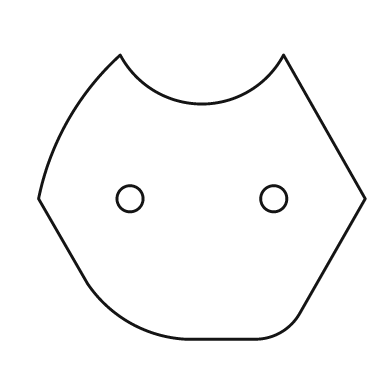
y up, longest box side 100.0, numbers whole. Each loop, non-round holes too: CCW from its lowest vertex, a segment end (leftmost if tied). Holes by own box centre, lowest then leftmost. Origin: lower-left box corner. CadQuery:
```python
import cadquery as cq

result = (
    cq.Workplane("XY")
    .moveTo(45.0, 0.0)
    .lineTo(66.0, 0.0)
    .threePointArc((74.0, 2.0), (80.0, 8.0))
    .lineTo(100.0, 43.0)
    .lineTo(75.0, 87.0)
    .threePointArc((50.0, 72.0), (25.0, 87.0))
    .threePointArc((9.0, 67.0), (0.0, 43.0))
    .lineTo(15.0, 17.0)
    .threePointArc((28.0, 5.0), (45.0, 0.0))
    .close()
    .moveTo(28.0, 43.0)
    .circle(4.0)
    .moveTo(72.0, 43.0)
    .circle(4.0)
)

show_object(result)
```